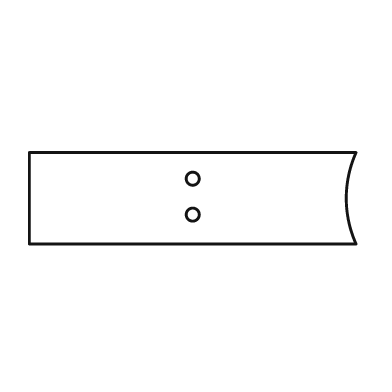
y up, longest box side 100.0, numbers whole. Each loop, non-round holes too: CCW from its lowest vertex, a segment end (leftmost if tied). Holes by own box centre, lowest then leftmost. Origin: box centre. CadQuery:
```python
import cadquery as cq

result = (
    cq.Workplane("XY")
    .moveTo(-50.0, -14.0)
    .lineTo(50.0, -14.0)
    .threePointArc((47.0, 0.0), (50.0, 14.0))
    .lineTo(-50.0, 14.0)
    .close()
    .moveTo(0.0, -5.0)
    .circle(2.0)
    .moveTo(0.0, 6.0)
    .circle(2.0)
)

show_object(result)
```